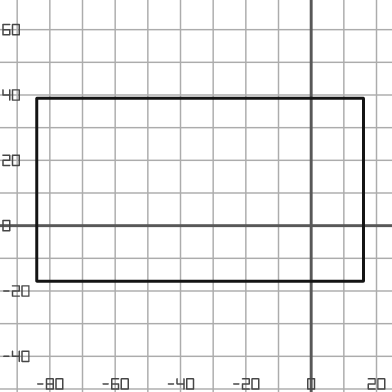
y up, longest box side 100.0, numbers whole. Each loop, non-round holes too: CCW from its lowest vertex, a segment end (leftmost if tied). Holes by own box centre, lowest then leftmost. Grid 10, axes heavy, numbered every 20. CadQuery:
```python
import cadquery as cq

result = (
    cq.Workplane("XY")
    .moveTo(-84.0, -17.0)
    .lineTo(16.0, -17.0)
    .lineTo(16.0, 39.0)
    .lineTo(-84.0, 39.0)
    .close()
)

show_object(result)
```